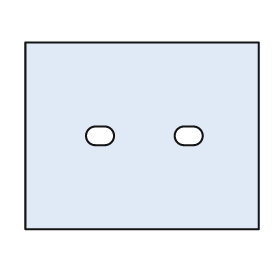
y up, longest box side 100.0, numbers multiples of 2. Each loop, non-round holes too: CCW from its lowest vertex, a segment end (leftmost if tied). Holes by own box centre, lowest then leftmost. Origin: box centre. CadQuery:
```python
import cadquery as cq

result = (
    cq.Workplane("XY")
    .moveTo(-50.0, -40.0)
    .lineTo(50.0, -40.0)
    .lineTo(50.0, 40.0)
    .lineTo(-50.0, 40.0)
    .close()
    .moveTo(-20.0, -4.0)
    .lineTo(-16.0, -4.0)
    .threePointArc((-12.0, 0.0), (-16.0, 4.0))
    .lineTo(-20.0, 4.0)
    .threePointArc((-24.0, 0.0), (-20.0, -4.0))
    .close()
    .moveTo(18.0, -4.0)
    .lineTo(22.0, -4.0)
    .threePointArc((26.0, 0.0), (22.0, 4.0))
    .lineTo(18.0, 4.0)
    .threePointArc((14.0, 0.0), (18.0, -4.0))
    .close()
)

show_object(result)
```